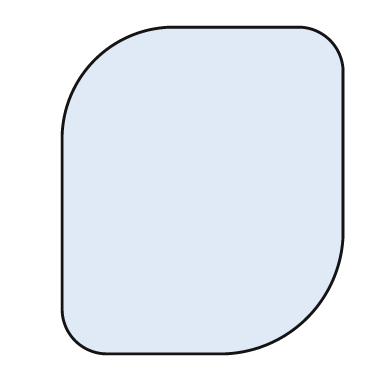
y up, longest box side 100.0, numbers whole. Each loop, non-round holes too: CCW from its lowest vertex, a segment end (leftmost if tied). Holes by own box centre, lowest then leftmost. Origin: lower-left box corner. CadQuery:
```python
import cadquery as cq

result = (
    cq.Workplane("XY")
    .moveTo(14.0, 0.0)
    .lineTo(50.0, 0.0)
    .threePointArc((75.0, 11.0), (86.0, 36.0))
    .lineTo(86.0, 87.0)
    .threePointArc((82.0, 96.0), (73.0, 100.0))
    .lineTo(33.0, 100.0)
    .threePointArc((10.0, 90.0), (0.0, 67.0))
    .lineTo(0.0, 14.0)
    .threePointArc((4.0, 4.0), (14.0, 0.0))
    .close()
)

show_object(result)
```